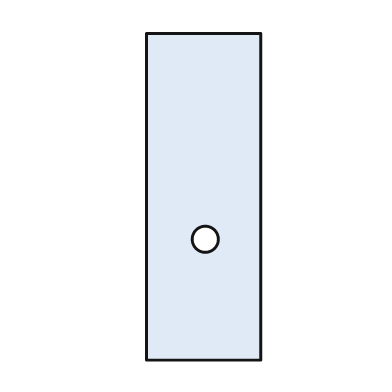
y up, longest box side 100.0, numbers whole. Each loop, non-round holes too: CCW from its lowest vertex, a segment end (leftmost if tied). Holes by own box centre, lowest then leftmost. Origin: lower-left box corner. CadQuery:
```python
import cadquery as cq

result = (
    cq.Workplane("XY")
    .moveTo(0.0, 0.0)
    .lineTo(35.0, 0.0)
    .lineTo(35.0, 100.0)
    .lineTo(0.0, 100.0)
    .close()
    .moveTo(18.0, 37.0)
    .circle(4.0)
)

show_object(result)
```